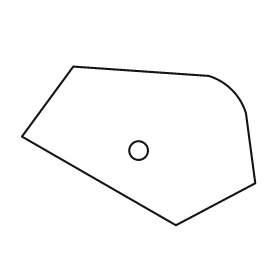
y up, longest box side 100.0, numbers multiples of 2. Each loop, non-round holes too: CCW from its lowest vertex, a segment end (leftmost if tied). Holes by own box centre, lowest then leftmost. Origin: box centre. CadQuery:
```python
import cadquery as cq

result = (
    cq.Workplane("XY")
    .moveTo(16.0, -34.0)
    .lineTo(50.0, -16.0)
    .lineTo(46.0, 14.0)
    .threePointArc((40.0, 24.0), (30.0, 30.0))
    .lineTo(-28.0, 34.0)
    .lineTo(-50.0, 4.0)
    .close()
    .moveTo(0.0, -2.0)
    .circle(4.0)
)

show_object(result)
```